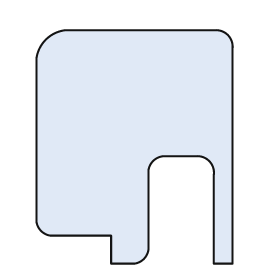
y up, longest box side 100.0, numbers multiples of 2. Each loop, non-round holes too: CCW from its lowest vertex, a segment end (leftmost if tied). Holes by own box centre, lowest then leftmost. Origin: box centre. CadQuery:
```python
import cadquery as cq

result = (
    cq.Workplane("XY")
    .moveTo(-10.0, -50.0)
    .lineTo(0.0, -50.0)
    .threePointArc((4.0, -48.0), (6.0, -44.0))
    .lineTo(6.0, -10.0)
    .threePointArc((8.0, -6.0), (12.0, -4.0))
    .lineTo(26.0, -4.0)
    .threePointArc((32.0, -6.0), (34.0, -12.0))
    .lineTo(34.0, -50.0)
    .lineTo(42.0, -50.0)
    .lineTo(42.0, 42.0)
    .threePointArc((40.0, 48.0), (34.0, 50.0))
    .lineTo(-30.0, 50.0)
    .threePointArc((-38.0, 46.0), (-42.0, 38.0))
    .lineTo(-42.0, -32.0)
    .threePointArc((-40.0, -36.0), (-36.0, -38.0))
    .lineTo(-10.0, -38.0)
    .close()
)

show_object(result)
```